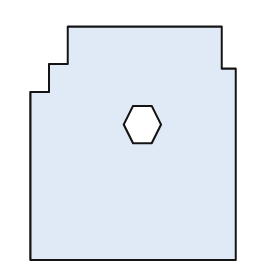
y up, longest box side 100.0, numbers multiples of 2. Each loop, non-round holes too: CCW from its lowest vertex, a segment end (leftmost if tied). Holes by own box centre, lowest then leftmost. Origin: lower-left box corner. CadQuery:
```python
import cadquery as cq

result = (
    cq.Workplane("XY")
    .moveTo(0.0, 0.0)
    .lineTo(88.0, 0.0)
    .lineTo(88.0, 82.0)
    .lineTo(82.0, 82.0)
    .lineTo(82.0, 100.0)
    .lineTo(16.0, 100.0)
    .lineTo(16.0, 84.0)
    .lineTo(8.0, 84.0)
    .lineTo(8.0, 72.0)
    .lineTo(0.0, 72.0)
    .close()
    .moveTo(44.0, 50.0)
    .lineTo(52.0, 50.0)
    .lineTo(56.0, 58.0)
    .lineTo(52.0, 66.0)
    .lineTo(44.0, 66.0)
    .lineTo(40.0, 58.0)
    .close()
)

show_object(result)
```